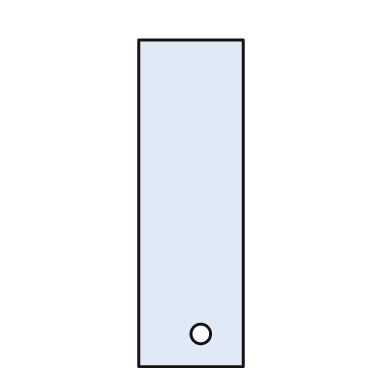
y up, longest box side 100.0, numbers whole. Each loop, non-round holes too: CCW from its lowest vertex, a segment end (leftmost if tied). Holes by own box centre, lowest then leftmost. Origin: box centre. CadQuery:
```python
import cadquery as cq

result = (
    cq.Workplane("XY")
    .moveTo(-16.0, -50.0)
    .lineTo(16.0, -50.0)
    .lineTo(16.0, 50.0)
    .lineTo(-16.0, 50.0)
    .close()
    .moveTo(3.0, -40.0)
    .circle(3.0)
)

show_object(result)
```